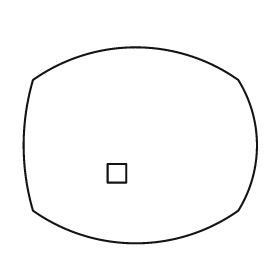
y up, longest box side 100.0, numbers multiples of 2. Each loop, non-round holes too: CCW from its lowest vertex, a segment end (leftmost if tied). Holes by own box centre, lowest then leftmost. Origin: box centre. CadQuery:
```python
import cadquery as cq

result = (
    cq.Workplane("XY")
    .moveTo(-46.0, -28.0)
    .threePointArc((-2.0, -42.0), (42.0, -28.0))
    .threePointArc((50.0, 0.0), (42.0, 28.0))
    .threePointArc((-2.0, 42.0), (-46.0, 28.0))
    .threePointArc((-50.0, 0.0), (-46.0, -28.0))
    .close()
    .moveTo(-14.0, -16.0)
    .lineTo(-6.0, -16.0)
    .lineTo(-6.0, -8.0)
    .lineTo(-14.0, -8.0)
    .close()
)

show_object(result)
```